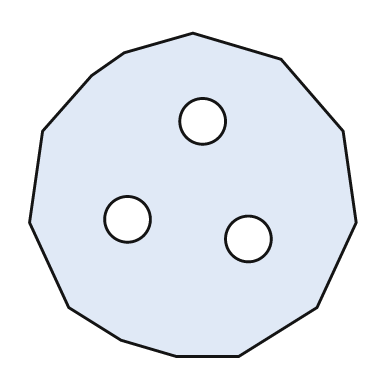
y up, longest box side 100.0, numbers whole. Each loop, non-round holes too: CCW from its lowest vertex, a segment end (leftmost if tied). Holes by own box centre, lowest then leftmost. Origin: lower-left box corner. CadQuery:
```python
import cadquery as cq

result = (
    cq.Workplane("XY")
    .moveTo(45.0, 0.0)
    .lineTo(64.0, 0.0)
    .lineTo(88.0, 15.0)
    .lineTo(100.0, 41.0)
    .lineTo(96.0, 69.0)
    .lineTo(77.0, 91.0)
    .lineTo(50.0, 99.0)
    .lineTo(29.0, 93.0)
    .lineTo(19.0, 86.0)
    .lineTo(4.0, 69.0)
    .lineTo(0.0, 41.0)
    .lineTo(12.0, 15.0)
    .lineTo(28.0, 5.0)
    .close()
    .moveTo(67.0, 36.0)
    .circle(7.0)
    .moveTo(30.0, 42.0)
    .circle(7.0)
    .moveTo(53.0, 72.0)
    .circle(7.0)
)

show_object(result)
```